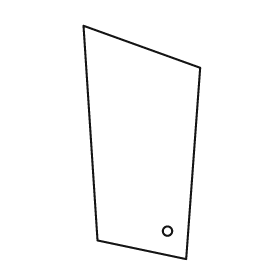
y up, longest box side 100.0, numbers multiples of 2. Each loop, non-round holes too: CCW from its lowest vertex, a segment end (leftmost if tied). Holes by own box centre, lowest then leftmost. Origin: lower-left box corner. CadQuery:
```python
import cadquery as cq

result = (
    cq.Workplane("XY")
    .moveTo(44.0, 0.0)
    .lineTo(50.0, 82.0)
    .lineTo(0.0, 100.0)
    .lineTo(6.0, 8.0)
    .close()
    .moveTo(36.0, 12.0)
    .circle(2.0)
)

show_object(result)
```